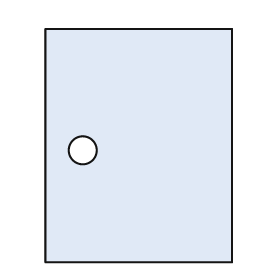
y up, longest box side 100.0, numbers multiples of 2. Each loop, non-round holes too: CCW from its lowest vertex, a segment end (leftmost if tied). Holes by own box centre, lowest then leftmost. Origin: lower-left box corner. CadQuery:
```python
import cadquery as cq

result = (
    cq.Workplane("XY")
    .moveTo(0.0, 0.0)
    .lineTo(80.0, 0.0)
    .lineTo(80.0, 100.0)
    .lineTo(0.0, 100.0)
    .close()
    .moveTo(16.0, 48.0)
    .circle(6.0)
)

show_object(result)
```